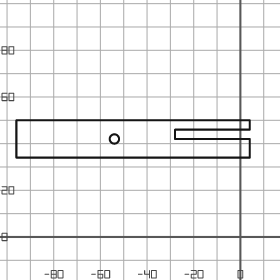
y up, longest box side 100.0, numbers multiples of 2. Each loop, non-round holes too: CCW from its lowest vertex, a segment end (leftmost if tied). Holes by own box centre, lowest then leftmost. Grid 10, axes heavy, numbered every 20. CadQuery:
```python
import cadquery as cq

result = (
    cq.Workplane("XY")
    .moveTo(-96.0, 34.0)
    .lineTo(4.0, 34.0)
    .lineTo(4.0, 42.0)
    .lineTo(-28.0, 42.0)
    .lineTo(-28.0, 46.0)
    .lineTo(4.0, 46.0)
    .lineTo(4.0, 50.0)
    .lineTo(-96.0, 50.0)
    .close()
    .moveTo(-54.0, 42.0)
    .circle(2.0)
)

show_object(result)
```